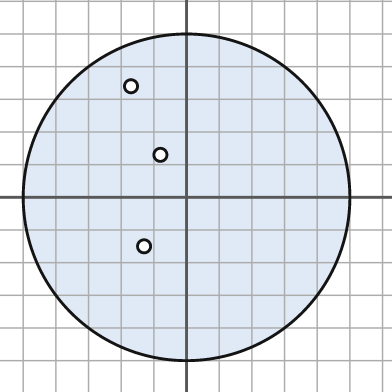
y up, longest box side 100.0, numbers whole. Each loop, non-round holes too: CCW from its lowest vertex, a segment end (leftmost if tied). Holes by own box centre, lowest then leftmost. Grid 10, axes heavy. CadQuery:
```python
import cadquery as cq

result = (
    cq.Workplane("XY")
    .moveTo(0.0, 0.0)
    .circle(50.0)
    .moveTo(-13.0, -15.0)
    .circle(2.0)
    .moveTo(-8.0, 13.0)
    .circle(2.0)
    .moveTo(-17.0, 34.0)
    .circle(2.0)
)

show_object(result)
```